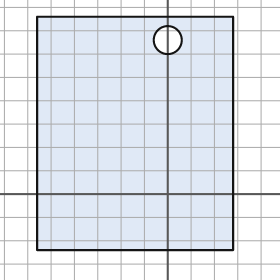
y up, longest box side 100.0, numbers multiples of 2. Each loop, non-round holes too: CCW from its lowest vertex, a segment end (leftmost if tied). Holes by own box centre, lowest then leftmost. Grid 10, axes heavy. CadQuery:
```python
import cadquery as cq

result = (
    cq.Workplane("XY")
    .moveTo(-56.0, -24.0)
    .lineTo(28.0, -24.0)
    .lineTo(28.0, 76.0)
    .lineTo(-56.0, 76.0)
    .close()
    .moveTo(0.0, 66.0)
    .circle(6.0)
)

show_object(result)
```